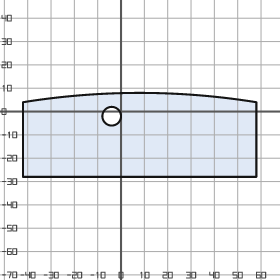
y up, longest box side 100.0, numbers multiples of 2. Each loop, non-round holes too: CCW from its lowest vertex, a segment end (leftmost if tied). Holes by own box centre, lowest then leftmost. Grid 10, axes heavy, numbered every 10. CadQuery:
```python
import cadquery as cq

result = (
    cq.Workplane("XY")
    .moveTo(-42.0, -28.0)
    .lineTo(58.0, -28.0)
    .lineTo(58.0, 4.0)
    .threePointArc((8.0, 8.0), (-42.0, 4.0))
    .close()
    .moveTo(-4.0, -2.0)
    .circle(4.0)
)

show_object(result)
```